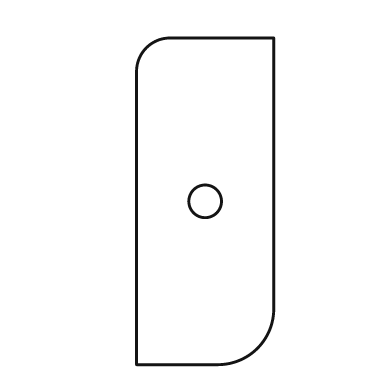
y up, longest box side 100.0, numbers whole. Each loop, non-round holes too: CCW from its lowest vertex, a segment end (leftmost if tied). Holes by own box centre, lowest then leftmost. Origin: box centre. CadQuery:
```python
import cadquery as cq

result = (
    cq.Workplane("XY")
    .moveTo(-21.0, -50.0)
    .lineTo(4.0, -50.0)
    .threePointArc((16.0, -45.0), (21.0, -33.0))
    .lineTo(21.0, 50.0)
    .lineTo(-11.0, 50.0)
    .threePointArc((-18.0, 47.0), (-21.0, 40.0))
    .close()
    .moveTo(0.0, 0.0)
    .circle(5.0)
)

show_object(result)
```